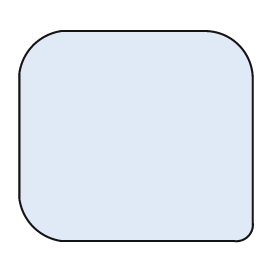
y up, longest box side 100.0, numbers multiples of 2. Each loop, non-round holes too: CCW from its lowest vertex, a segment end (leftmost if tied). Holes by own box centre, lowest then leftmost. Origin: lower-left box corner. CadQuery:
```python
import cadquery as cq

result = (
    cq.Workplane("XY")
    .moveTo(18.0, 0.0)
    .lineTo(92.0, 0.0)
    .threePointArc((98.0, 2.0), (100.0, 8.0))
    .lineTo(100.0, 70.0)
    .threePointArc((94.0, 84.0), (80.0, 90.0))
    .lineTo(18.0, 90.0)
    .threePointArc((6.0, 84.0), (0.0, 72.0))
    .lineTo(0.0, 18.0)
    .threePointArc((6.0, 6.0), (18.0, 0.0))
    .close()
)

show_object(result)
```